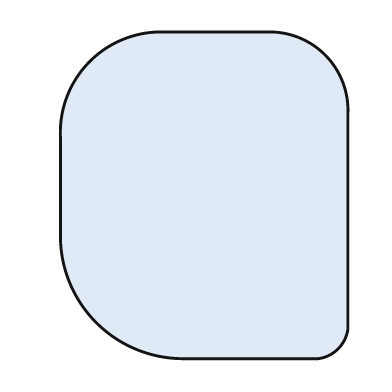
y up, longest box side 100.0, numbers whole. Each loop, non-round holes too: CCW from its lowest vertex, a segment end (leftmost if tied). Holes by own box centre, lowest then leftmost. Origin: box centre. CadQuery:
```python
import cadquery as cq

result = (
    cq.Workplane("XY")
    .moveTo(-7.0, -50.0)
    .lineTo(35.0, -50.0)
    .threePointArc((41.0, -47.0), (44.0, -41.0))
    .lineTo(44.0, 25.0)
    .threePointArc((37.0, 43.0), (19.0, 50.0))
    .lineTo(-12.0, 50.0)
    .threePointArc((-35.0, 41.0), (-44.0, 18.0))
    .lineTo(-44.0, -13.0)
    .threePointArc((-33.0, -39.0), (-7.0, -50.0))
    .close()
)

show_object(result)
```